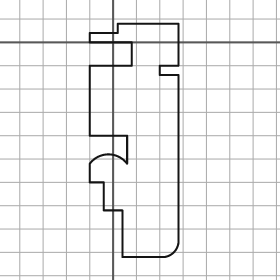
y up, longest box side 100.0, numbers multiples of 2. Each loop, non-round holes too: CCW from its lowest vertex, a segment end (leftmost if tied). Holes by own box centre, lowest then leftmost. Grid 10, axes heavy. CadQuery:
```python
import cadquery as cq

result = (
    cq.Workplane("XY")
    .moveTo(4.0, -92.0)
    .lineTo(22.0, -92.0)
    .threePointArc((26.0, -90.0), (28.0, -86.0))
    .lineTo(28.0, -14.0)
    .lineTo(20.0, -14.0)
    .lineTo(20.0, -10.0)
    .lineTo(28.0, -10.0)
    .lineTo(28.0, 8.0)
    .lineTo(2.0, 8.0)
    .lineTo(2.0, 4.0)
    .lineTo(-10.0, 4.0)
    .lineTo(-10.0, 0.0)
    .lineTo(8.0, 0.0)
    .lineTo(8.0, -10.0)
    .lineTo(-10.0, -10.0)
    .lineTo(-10.0, -40.0)
    .lineTo(6.0, -40.0)
    .lineTo(6.0, -52.0)
    .threePointArc((-2.0, -48.0), (-10.0, -52.0))
    .lineTo(-10.0, -60.0)
    .lineTo(-4.0, -60.0)
    .lineTo(-4.0, -72.0)
    .lineTo(4.0, -72.0)
    .close()
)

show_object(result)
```